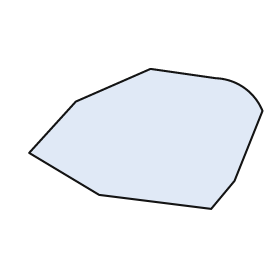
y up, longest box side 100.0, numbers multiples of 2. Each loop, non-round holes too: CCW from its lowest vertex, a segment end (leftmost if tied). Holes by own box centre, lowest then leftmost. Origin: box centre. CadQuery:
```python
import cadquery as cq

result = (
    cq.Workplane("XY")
    .moveTo(28.0, -30.0)
    .lineTo(38.0, -18.0)
    .lineTo(50.0, 12.0)
    .threePointArc((42.0, 22.0), (30.0, 26.0))
    .lineTo(2.0, 30.0)
    .lineTo(-30.0, 16.0)
    .lineTo(-50.0, -6.0)
    .lineTo(-20.0, -24.0)
    .close()
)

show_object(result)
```